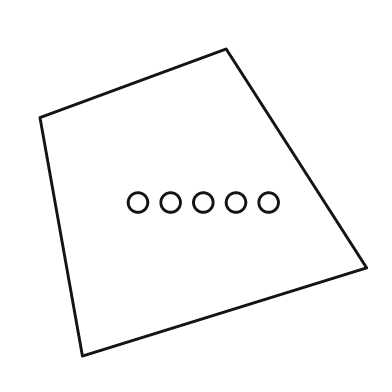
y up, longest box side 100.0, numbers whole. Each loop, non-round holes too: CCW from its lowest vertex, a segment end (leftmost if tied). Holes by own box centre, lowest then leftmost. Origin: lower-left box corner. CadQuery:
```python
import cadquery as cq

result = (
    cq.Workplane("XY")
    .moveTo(13.0, 0.0)
    .lineTo(100.0, 27.0)
    .lineTo(57.0, 94.0)
    .lineTo(0.0, 73.0)
    .close()
    .moveTo(30.0, 47.0)
    .circle(3.0)
    .moveTo(40.0, 47.0)
    .circle(3.0)
    .moveTo(50.0, 47.0)
    .circle(3.0)
    .moveTo(60.0, 47.0)
    .circle(3.0)
    .moveTo(70.0, 47.0)
    .circle(3.0)
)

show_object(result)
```